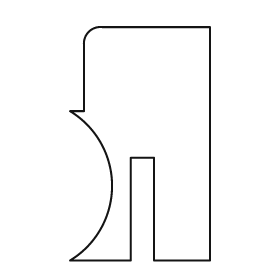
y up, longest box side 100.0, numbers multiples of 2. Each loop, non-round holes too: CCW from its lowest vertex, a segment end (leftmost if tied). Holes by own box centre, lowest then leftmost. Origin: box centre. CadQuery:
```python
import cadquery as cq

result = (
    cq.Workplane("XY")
    .moveTo(-30.0, -50.0)
    .lineTo(-4.0, -50.0)
    .lineTo(-4.0, -6.0)
    .lineTo(6.0, -6.0)
    .lineTo(6.0, -50.0)
    .lineTo(30.0, -50.0)
    .lineTo(30.0, 50.0)
    .lineTo(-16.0, 50.0)
    .threePointArc((-22.0, 48.0), (-24.0, 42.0))
    .lineTo(-24.0, 14.0)
    .lineTo(-30.0, 14.0)
    .threePointArc((-12.0, -18.0), (-30.0, -50.0))
    .close()
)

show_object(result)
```